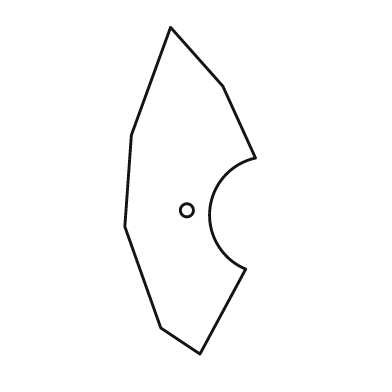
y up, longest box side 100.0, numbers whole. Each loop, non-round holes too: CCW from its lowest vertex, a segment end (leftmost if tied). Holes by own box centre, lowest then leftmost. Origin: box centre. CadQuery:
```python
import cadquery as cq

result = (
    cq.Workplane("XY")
    .moveTo(3.0, -50.0)
    .lineTo(17.0, -24.0)
    .threePointArc((6.0, -6.0), (20.0, 10.0))
    .lineTo(10.0, 32.0)
    .lineTo(-6.0, 50.0)
    .lineTo(-18.0, 17.0)
    .lineTo(-20.0, -11.0)
    .lineTo(-9.0, -42.0)
    .close()
    .moveTo(-1.0, -6.0)
    .circle(2.0)
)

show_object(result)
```